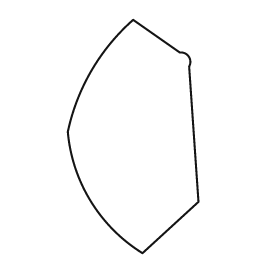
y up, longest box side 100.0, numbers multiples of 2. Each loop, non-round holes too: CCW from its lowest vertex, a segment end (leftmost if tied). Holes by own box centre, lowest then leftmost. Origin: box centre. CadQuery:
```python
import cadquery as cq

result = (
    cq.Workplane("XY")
    .moveTo(4.0, -50.0)
    .lineTo(28.0, -28.0)
    .lineTo(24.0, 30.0)
    .threePointArc((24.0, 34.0), (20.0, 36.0))
    .lineTo(0.0, 50.0)
    .threePointArc((-18.0, 28.0), (-28.0, 2.0))
    .threePointArc((-18.0, -28.0), (4.0, -50.0))
    .close()
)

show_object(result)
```